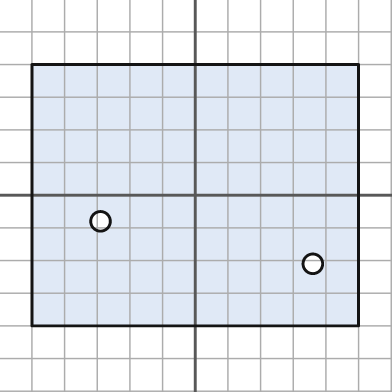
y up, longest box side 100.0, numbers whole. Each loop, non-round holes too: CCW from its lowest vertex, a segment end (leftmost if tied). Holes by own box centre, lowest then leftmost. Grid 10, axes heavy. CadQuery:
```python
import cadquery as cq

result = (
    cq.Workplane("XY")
    .moveTo(-50.0, -40.0)
    .lineTo(50.0, -40.0)
    .lineTo(50.0, 40.0)
    .lineTo(-50.0, 40.0)
    .close()
    .moveTo(36.0, -21.0)
    .circle(3.0)
    .moveTo(-29.0, -8.0)
    .circle(3.0)
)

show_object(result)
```